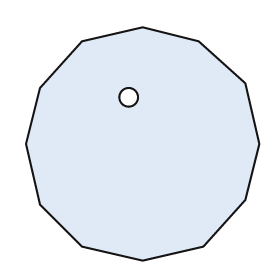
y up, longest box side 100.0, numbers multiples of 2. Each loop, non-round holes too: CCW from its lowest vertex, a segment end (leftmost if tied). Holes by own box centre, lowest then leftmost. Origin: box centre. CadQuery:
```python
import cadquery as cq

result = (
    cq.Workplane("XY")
    .moveTo(0.0, -50.0)
    .lineTo(26.0, -44.0)
    .lineTo(44.0, -24.0)
    .lineTo(50.0, 0.0)
    .lineTo(44.0, 26.0)
    .lineTo(24.0, 44.0)
    .lineTo(0.0, 50.0)
    .lineTo(-26.0, 44.0)
    .lineTo(-44.0, 24.0)
    .lineTo(-50.0, 0.0)
    .lineTo(-44.0, -26.0)
    .lineTo(-26.0, -44.0)
    .close()
    .moveTo(-6.0, 20.0)
    .circle(4.0)
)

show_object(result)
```